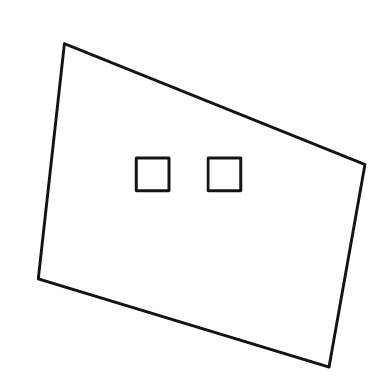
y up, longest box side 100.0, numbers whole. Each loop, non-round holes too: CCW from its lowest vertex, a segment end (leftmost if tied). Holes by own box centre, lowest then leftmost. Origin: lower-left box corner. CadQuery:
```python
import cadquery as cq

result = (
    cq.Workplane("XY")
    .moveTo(89.0, 0.0)
    .lineTo(100.0, 62.0)
    .lineTo(8.0, 99.0)
    .lineTo(0.0, 27.0)
    .close()
    .moveTo(30.0, 54.0)
    .lineTo(40.0, 54.0)
    .lineTo(40.0, 64.0)
    .lineTo(30.0, 64.0)
    .close()
    .moveTo(52.0, 54.0)
    .lineTo(62.0, 54.0)
    .lineTo(62.0, 64.0)
    .lineTo(52.0, 64.0)
    .close()
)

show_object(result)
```